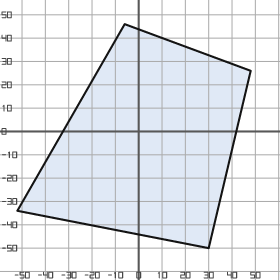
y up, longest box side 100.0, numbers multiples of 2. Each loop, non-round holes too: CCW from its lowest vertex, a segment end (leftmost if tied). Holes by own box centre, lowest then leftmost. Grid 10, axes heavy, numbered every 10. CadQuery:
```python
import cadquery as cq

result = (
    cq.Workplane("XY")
    .moveTo(30.0, -50.0)
    .lineTo(48.0, 26.0)
    .lineTo(-6.0, 46.0)
    .lineTo(-52.0, -34.0)
    .close()
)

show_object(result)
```